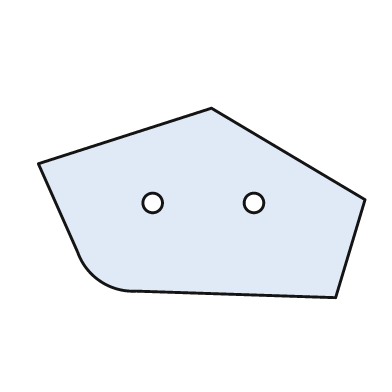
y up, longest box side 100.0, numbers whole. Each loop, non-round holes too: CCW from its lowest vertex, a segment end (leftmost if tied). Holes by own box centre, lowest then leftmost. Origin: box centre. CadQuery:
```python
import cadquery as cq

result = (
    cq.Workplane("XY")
    .moveTo(41.0, -29.0)
    .lineTo(50.0, 1.0)
    .lineTo(3.0, 29.0)
    .lineTo(-50.0, 12.0)
    .lineTo(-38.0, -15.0)
    .threePointArc((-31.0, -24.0), (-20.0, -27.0))
    .close()
    .moveTo(-15.0, 0.0)
    .circle(3.0)
    .moveTo(16.0, 0.0)
    .circle(3.0)
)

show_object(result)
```